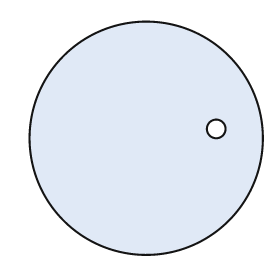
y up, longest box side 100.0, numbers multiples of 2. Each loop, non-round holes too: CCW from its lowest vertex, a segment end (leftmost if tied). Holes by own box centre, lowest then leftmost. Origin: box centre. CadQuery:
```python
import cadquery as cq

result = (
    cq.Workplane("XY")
    .moveTo(0.0, 0.0)
    .circle(50.0)
    .moveTo(30.0, 4.0)
    .circle(4.0)
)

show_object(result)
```